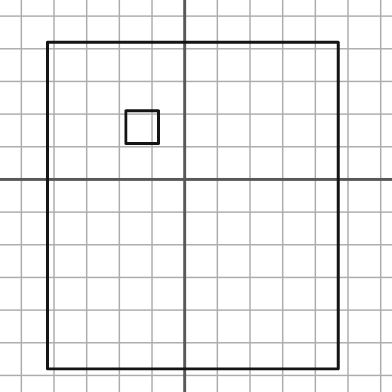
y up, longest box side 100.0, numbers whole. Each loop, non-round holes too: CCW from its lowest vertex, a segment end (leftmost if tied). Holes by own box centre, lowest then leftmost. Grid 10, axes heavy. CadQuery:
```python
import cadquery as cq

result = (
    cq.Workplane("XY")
    .moveTo(-42.0, -58.0)
    .lineTo(47.0, -58.0)
    .lineTo(47.0, 42.0)
    .lineTo(-42.0, 42.0)
    .close()
    .moveTo(-18.0, 11.0)
    .lineTo(-8.0, 11.0)
    .lineTo(-8.0, 21.0)
    .lineTo(-18.0, 21.0)
    .close()
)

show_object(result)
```